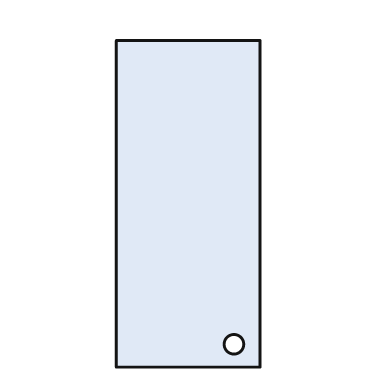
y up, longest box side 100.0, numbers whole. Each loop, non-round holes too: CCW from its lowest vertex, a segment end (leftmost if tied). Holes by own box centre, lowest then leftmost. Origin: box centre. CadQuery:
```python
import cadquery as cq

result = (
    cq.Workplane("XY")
    .moveTo(-22.0, -50.0)
    .lineTo(22.0, -50.0)
    .lineTo(22.0, 50.0)
    .lineTo(-22.0, 50.0)
    .close()
    .moveTo(14.0, -43.0)
    .circle(3.0)
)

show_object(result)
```